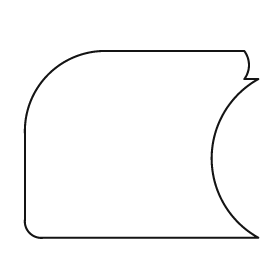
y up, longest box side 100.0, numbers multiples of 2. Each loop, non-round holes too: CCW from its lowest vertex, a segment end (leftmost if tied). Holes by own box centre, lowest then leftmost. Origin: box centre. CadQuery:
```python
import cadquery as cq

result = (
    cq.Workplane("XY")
    .moveTo(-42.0, -40.0)
    .lineTo(50.0, -40.0)
    .threePointArc((30.0, -6.0), (50.0, 28.0))
    .lineTo(44.0, 28.0)
    .threePointArc((46.0, 34.0), (44.0, 40.0))
    .lineTo(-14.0, 40.0)
    .threePointArc((-40.0, 30.0), (-50.0, 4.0))
    .lineTo(-50.0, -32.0)
    .threePointArc((-48.0, -38.0), (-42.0, -40.0))
    .close()
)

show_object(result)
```